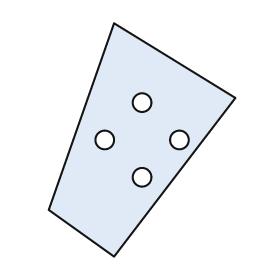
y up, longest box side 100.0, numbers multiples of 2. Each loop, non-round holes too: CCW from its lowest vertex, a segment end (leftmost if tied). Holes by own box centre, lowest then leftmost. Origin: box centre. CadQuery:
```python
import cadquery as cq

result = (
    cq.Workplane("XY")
    .moveTo(-12.0, -50.0)
    .lineTo(40.0, 18.0)
    .lineTo(-12.0, 50.0)
    .lineTo(-40.0, -30.0)
    .close()
    .moveTo(0.0, -16.0)
    .circle(4.0)
    .moveTo(-16.0, 0.0)
    .circle(4.0)
    .moveTo(16.0, 0.0)
    .circle(4.0)
    .moveTo(0.0, 16.0)
    .circle(4.0)
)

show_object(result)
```